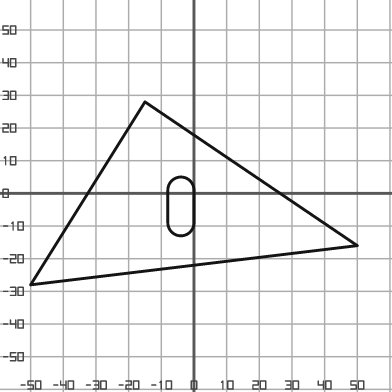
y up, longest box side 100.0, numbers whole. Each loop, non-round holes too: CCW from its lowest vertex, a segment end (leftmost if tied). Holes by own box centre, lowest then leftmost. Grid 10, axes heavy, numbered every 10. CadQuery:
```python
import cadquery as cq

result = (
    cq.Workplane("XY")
    .moveTo(-50.0, -28.0)
    .lineTo(50.0, -16.0)
    .lineTo(-15.0, 28.0)
    .close()
    .moveTo(-8.0, -9.0)
    .threePointArc((-4.0, -13.0), (0.0, -9.0))
    .lineTo(0.0, 1.0)
    .threePointArc((-4.0, 5.0), (-8.0, 1.0))
    .close()
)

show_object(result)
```